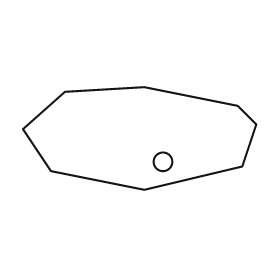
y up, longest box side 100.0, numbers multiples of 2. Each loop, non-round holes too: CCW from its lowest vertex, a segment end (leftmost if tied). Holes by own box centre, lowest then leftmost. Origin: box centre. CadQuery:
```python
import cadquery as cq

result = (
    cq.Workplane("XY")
    .moveTo(2.0, -22.0)
    .lineTo(44.0, -12.0)
    .lineTo(50.0, 6.0)
    .lineTo(42.0, 14.0)
    .lineTo(2.0, 22.0)
    .lineTo(-32.0, 20.0)
    .lineTo(-50.0, 4.0)
    .lineTo(-38.0, -14.0)
    .close()
    .moveTo(10.0, -10.0)
    .circle(4.0)
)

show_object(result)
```